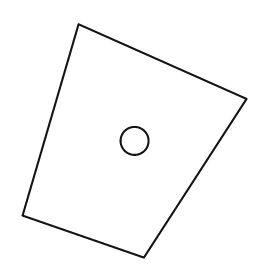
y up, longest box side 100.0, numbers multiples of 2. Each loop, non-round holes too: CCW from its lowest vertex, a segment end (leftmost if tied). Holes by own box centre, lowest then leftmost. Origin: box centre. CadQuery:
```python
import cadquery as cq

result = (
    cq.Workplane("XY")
    .moveTo(4.0, -50.0)
    .lineTo(48.0, 18.0)
    .lineTo(-24.0, 50.0)
    .lineTo(-48.0, -32.0)
    .close()
    .moveTo(0.0, 0.0)
    .circle(6.0)
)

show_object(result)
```